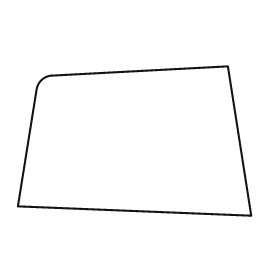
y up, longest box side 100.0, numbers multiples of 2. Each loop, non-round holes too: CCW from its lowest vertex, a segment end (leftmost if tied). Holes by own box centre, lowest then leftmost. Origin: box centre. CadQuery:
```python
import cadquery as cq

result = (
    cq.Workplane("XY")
    .moveTo(50.0, -32.0)
    .lineTo(40.0, 32.0)
    .lineTo(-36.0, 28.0)
    .threePointArc((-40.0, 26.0), (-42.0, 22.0))
    .lineTo(-50.0, -28.0)
    .close()
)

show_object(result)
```